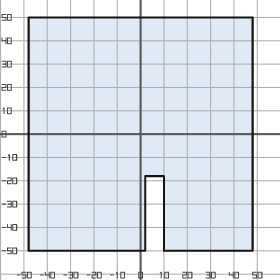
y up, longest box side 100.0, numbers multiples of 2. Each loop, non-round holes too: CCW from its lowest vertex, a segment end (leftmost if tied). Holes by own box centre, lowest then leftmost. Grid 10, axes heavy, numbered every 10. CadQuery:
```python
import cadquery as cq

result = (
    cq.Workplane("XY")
    .moveTo(-48.0, -50.0)
    .lineTo(2.0, -50.0)
    .lineTo(2.0, -18.0)
    .lineTo(10.0, -18.0)
    .lineTo(10.0, -50.0)
    .lineTo(48.0, -50.0)
    .lineTo(48.0, 50.0)
    .lineTo(-48.0, 50.0)
    .close()
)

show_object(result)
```